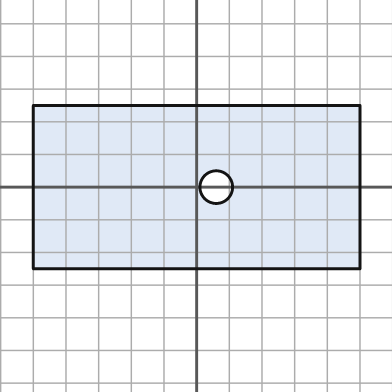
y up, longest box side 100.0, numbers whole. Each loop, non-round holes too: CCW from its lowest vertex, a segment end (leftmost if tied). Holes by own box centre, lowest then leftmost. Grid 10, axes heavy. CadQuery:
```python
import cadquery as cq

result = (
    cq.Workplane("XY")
    .moveTo(-50.0, -25.0)
    .lineTo(50.0, -25.0)
    .lineTo(50.0, 25.0)
    .lineTo(-50.0, 25.0)
    .close()
    .moveTo(6.0, 0.0)
    .circle(5.0)
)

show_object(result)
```